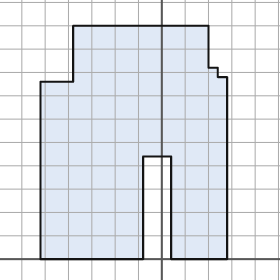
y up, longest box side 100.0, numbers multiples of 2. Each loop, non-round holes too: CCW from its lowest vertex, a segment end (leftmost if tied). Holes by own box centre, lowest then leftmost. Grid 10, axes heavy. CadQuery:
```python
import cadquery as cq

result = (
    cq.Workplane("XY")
    .moveTo(-52.0, 0.0)
    .lineTo(-8.0, 0.0)
    .lineTo(-8.0, 44.0)
    .lineTo(4.0, 44.0)
    .lineTo(4.0, 0.0)
    .lineTo(28.0, 0.0)
    .lineTo(28.0, 78.0)
    .lineTo(24.0, 78.0)
    .lineTo(24.0, 82.0)
    .lineTo(20.0, 82.0)
    .lineTo(20.0, 100.0)
    .lineTo(-38.0, 100.0)
    .lineTo(-38.0, 76.0)
    .lineTo(-52.0, 76.0)
    .close()
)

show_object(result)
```